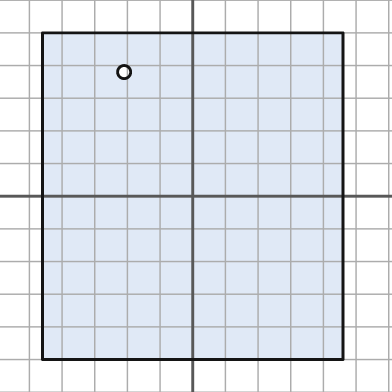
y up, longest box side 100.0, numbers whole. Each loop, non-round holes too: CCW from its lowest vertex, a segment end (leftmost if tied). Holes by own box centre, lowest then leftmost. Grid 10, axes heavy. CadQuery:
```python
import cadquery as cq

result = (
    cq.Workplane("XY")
    .moveTo(-46.0, -50.0)
    .lineTo(46.0, -50.0)
    .lineTo(46.0, 50.0)
    .lineTo(-46.0, 50.0)
    .close()
    .moveTo(-21.0, 38.0)
    .circle(2.0)
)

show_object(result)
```